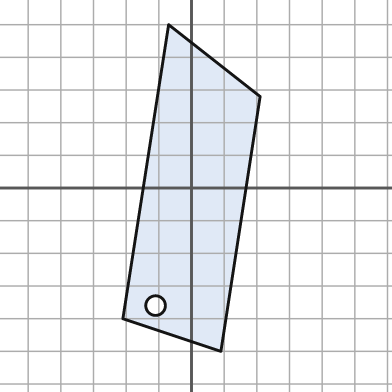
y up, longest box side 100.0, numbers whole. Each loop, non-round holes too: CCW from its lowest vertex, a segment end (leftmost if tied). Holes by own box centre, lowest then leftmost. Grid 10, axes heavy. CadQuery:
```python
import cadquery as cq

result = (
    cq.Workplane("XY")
    .moveTo(9.0, -50.0)
    .lineTo(21.0, 28.0)
    .lineTo(-7.0, 50.0)
    .lineTo(-21.0, -40.0)
    .close()
    .moveTo(-11.0, -36.0)
    .circle(3.0)
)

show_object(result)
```